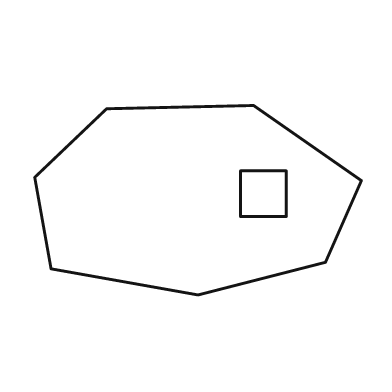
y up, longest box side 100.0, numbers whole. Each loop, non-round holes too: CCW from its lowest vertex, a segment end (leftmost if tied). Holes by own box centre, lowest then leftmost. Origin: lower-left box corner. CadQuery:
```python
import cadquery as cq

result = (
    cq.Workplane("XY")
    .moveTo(50.0, 0.0)
    .lineTo(89.0, 10.0)
    .lineTo(100.0, 35.0)
    .lineTo(67.0, 58.0)
    .lineTo(22.0, 57.0)
    .lineTo(0.0, 36.0)
    .lineTo(5.0, 8.0)
    .close()
    .moveTo(63.0, 24.0)
    .lineTo(77.0, 24.0)
    .lineTo(77.0, 38.0)
    .lineTo(63.0, 38.0)
    .close()
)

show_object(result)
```